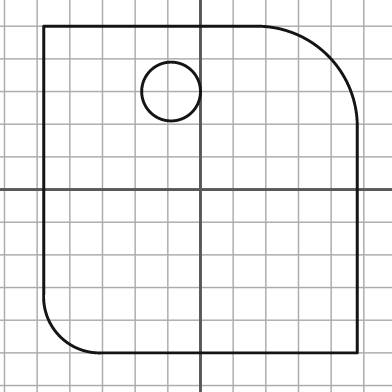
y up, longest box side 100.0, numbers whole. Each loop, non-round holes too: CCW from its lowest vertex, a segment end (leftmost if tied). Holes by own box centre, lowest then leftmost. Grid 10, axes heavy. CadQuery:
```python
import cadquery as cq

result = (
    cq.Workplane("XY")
    .moveTo(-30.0, -50.0)
    .lineTo(48.0, -50.0)
    .lineTo(48.0, 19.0)
    .threePointArc((39.0, 41.0), (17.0, 50.0))
    .lineTo(-48.0, 50.0)
    .lineTo(-48.0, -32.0)
    .threePointArc((-43.0, -45.0), (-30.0, -50.0))
    .close()
    .moveTo(-9.0, 30.0)
    .circle(9.0)
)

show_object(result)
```